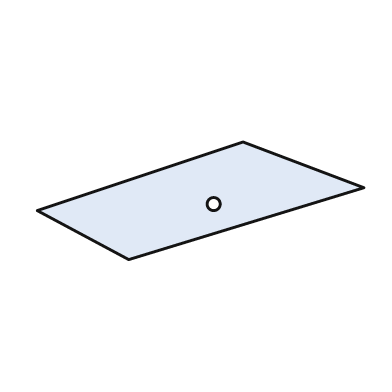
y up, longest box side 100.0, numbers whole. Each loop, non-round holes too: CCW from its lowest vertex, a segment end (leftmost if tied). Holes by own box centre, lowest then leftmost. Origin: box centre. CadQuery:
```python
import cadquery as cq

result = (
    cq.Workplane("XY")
    .moveTo(-22.0, -18.0)
    .lineTo(50.0, 4.0)
    .lineTo(13.0, 18.0)
    .lineTo(-50.0, -3.0)
    .close()
    .moveTo(4.0, -1.0)
    .circle(2.0)
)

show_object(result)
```